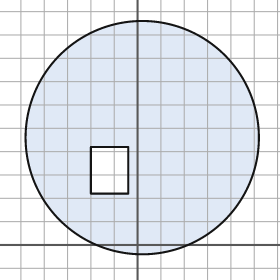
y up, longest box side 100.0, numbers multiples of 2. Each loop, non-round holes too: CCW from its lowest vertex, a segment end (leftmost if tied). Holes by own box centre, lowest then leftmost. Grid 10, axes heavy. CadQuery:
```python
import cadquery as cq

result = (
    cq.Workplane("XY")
    .moveTo(2.0, 46.0)
    .circle(50.0)
    .moveTo(-20.0, 22.0)
    .lineTo(-4.0, 22.0)
    .lineTo(-4.0, 42.0)
    .lineTo(-20.0, 42.0)
    .close()
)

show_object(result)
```